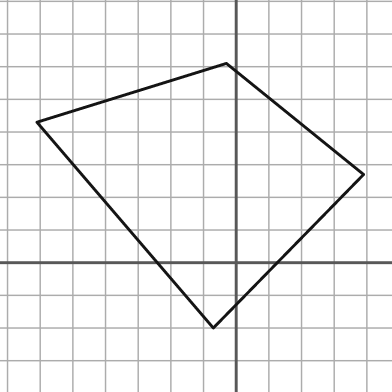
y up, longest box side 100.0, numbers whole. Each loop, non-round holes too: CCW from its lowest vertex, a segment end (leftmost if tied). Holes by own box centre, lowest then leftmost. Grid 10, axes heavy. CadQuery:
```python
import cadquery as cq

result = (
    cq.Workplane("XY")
    .moveTo(-7.0, -20.0)
    .lineTo(39.0, 27.0)
    .lineTo(-3.0, 61.0)
    .lineTo(-61.0, 43.0)
    .close()
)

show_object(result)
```